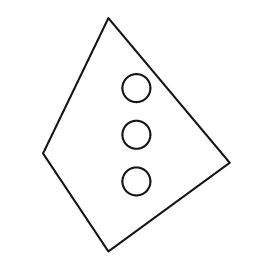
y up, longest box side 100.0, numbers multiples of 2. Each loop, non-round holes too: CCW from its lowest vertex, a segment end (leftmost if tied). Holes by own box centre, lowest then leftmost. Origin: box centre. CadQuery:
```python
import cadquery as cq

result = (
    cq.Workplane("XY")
    .moveTo(-12.0, -50.0)
    .lineTo(40.0, -12.0)
    .lineTo(-12.0, 50.0)
    .lineTo(-40.0, -8.0)
    .close()
    .moveTo(0.0, -20.0)
    .circle(6.0)
    .moveTo(0.0, 0.0)
    .circle(6.0)
    .moveTo(0.0, 20.0)
    .circle(6.0)
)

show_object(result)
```